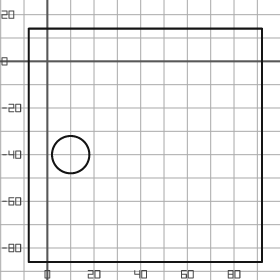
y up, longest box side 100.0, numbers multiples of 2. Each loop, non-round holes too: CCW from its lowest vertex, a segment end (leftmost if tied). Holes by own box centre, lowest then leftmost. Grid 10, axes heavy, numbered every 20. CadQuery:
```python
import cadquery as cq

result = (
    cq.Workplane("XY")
    .moveTo(-8.0, -86.0)
    .lineTo(92.0, -86.0)
    .lineTo(92.0, 14.0)
    .lineTo(-8.0, 14.0)
    .close()
    .moveTo(10.0, -40.0)
    .circle(8.0)
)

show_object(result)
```